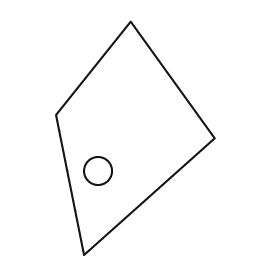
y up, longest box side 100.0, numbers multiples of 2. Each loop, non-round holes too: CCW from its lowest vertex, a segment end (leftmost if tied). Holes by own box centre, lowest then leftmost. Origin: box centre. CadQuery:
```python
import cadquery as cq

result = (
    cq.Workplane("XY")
    .moveTo(-22.0, -50.0)
    .lineTo(34.0, 0.0)
    .lineTo(-2.0, 50.0)
    .lineTo(-34.0, 10.0)
    .close()
    .moveTo(-16.0, -14.0)
    .circle(6.0)
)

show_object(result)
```